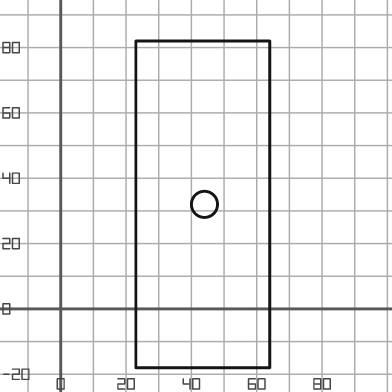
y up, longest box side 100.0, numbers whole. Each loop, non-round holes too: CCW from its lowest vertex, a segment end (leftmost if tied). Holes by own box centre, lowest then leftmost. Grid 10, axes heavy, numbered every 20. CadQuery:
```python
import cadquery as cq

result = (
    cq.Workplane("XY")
    .moveTo(23.0, -18.0)
    .lineTo(64.0, -18.0)
    .lineTo(64.0, 82.0)
    .lineTo(23.0, 82.0)
    .close()
    .moveTo(44.0, 32.0)
    .circle(4.0)
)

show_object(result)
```